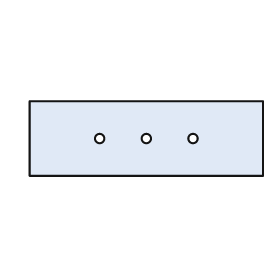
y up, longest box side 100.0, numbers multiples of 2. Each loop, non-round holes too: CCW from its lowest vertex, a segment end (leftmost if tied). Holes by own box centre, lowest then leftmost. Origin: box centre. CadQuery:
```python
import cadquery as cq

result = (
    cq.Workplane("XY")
    .moveTo(-50.0, -16.0)
    .lineTo(50.0, -16.0)
    .lineTo(50.0, 16.0)
    .lineTo(-50.0, 16.0)
    .close()
    .moveTo(-20.0, 0.0)
    .circle(2.0)
    .moveTo(0.0, 0.0)
    .circle(2.0)
    .moveTo(20.0, 0.0)
    .circle(2.0)
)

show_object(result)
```